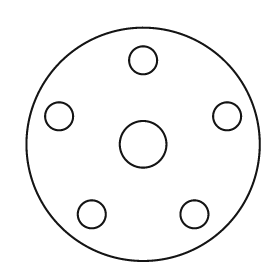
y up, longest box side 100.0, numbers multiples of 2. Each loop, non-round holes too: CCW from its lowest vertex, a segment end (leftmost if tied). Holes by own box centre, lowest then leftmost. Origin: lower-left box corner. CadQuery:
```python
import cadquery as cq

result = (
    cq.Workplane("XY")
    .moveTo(50.0, 50.0)
    .circle(50.0)
    .moveTo(28.0, 20.0)
    .circle(6.0)
    .moveTo(72.0, 20.0)
    .circle(6.0)
    .moveTo(50.0, 50.0)
    .circle(10.0)
    .moveTo(14.0, 62.0)
    .circle(6.0)
    .moveTo(86.0, 62.0)
    .circle(6.0)
    .moveTo(50.0, 86.0)
    .circle(6.0)
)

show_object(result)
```